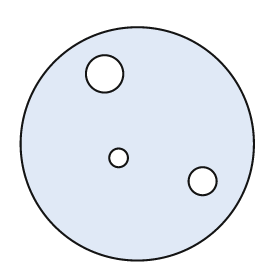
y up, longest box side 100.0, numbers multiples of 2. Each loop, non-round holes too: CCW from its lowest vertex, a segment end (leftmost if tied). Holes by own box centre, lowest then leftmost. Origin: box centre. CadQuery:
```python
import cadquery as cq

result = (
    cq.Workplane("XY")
    .moveTo(0.0, 0.0)
    .circle(50.0)
    .moveTo(28.0, -16.0)
    .circle(6.0)
    .moveTo(-8.0, -6.0)
    .circle(4.0)
    .moveTo(-14.0, 30.0)
    .circle(8.0)
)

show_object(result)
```